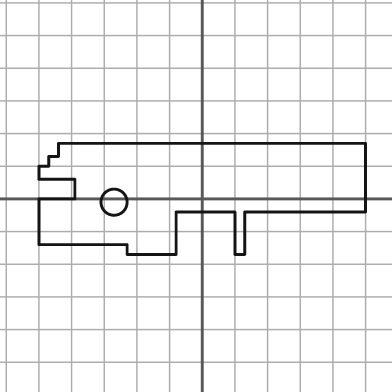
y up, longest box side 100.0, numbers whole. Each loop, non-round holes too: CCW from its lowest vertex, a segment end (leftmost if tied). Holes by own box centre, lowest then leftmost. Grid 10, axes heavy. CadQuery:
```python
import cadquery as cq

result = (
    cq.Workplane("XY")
    .moveTo(-23.0, -17.0)
    .lineTo(-8.0, -17.0)
    .lineTo(-8.0, -4.0)
    .lineTo(10.0, -4.0)
    .lineTo(10.0, -17.0)
    .lineTo(13.0, -17.0)
    .lineTo(13.0, -4.0)
    .lineTo(50.0, -4.0)
    .lineTo(50.0, 17.0)
    .lineTo(-44.0, 17.0)
    .lineTo(-44.0, 13.0)
    .lineTo(-47.0, 13.0)
    .lineTo(-47.0, 10.0)
    .lineTo(-50.0, 10.0)
    .lineTo(-50.0, 6.0)
    .lineTo(-39.0, 6.0)
    .lineTo(-39.0, 0.0)
    .lineTo(-50.0, 0.0)
    .lineTo(-50.0, -14.0)
    .lineTo(-23.0, -14.0)
    .close()
    .moveTo(-27.0, -1.0)
    .circle(4.0)
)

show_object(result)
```